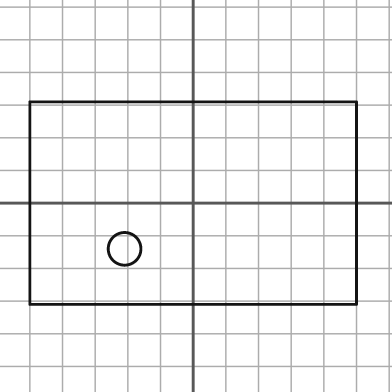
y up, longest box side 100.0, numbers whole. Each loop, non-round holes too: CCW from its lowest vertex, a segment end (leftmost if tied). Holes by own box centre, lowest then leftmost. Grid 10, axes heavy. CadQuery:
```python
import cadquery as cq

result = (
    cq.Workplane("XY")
    .moveTo(-50.0, -31.0)
    .lineTo(50.0, -31.0)
    .lineTo(50.0, 31.0)
    .lineTo(-50.0, 31.0)
    .close()
    .moveTo(-21.0, -14.0)
    .circle(5.0)
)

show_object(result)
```